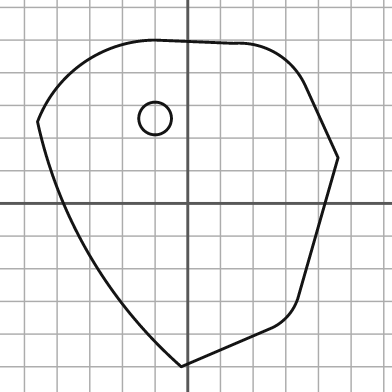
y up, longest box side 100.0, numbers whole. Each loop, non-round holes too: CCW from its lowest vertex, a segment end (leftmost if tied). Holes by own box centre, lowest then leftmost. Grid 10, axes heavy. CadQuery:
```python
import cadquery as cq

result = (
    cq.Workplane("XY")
    .moveTo(-2.0, -50.0)
    .lineTo(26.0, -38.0)
    .threePointArc((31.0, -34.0), (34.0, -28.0))
    .lineTo(46.0, 14.0)
    .lineTo(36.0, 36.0)
    .threePointArc((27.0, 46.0), (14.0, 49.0))
    .lineTo(-10.0, 50.0)
    .threePointArc((-32.0, 43.0), (-46.0, 25.0))
    .threePointArc((-30.0, -16.0), (-2.0, -50.0))
    .close()
    .moveTo(-10.0, 26.0)
    .circle(5.0)
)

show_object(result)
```